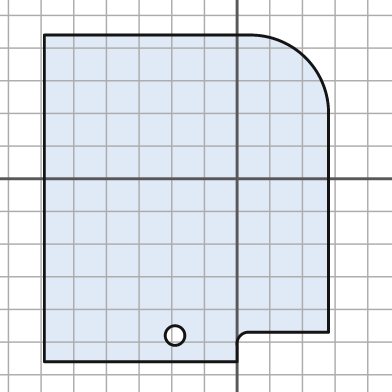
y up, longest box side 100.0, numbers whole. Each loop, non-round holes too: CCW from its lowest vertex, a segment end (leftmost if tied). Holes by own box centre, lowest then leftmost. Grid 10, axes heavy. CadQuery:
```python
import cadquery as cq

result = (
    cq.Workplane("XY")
    .moveTo(-59.0, -56.0)
    .lineTo(0.0, -56.0)
    .lineTo(0.0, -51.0)
    .threePointArc((1.0, -48.0), (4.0, -47.0))
    .lineTo(28.0, -47.0)
    .lineTo(28.0, 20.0)
    .threePointArc((21.0, 37.0), (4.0, 44.0))
    .lineTo(-59.0, 44.0)
    .close()
    .moveTo(-19.0, -48.0)
    .circle(3.0)
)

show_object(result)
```